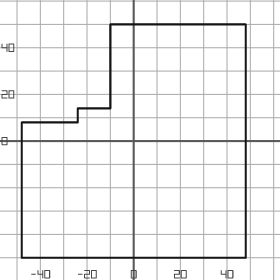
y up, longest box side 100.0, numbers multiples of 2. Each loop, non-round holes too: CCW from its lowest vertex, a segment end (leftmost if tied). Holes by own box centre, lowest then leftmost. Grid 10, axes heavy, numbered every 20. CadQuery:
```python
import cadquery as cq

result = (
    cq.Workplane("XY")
    .moveTo(-48.0, -50.0)
    .lineTo(48.0, -50.0)
    .lineTo(48.0, 50.0)
    .lineTo(-10.0, 50.0)
    .lineTo(-10.0, 14.0)
    .lineTo(-24.0, 14.0)
    .lineTo(-24.0, 8.0)
    .lineTo(-48.0, 8.0)
    .close()
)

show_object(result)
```